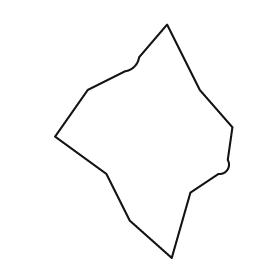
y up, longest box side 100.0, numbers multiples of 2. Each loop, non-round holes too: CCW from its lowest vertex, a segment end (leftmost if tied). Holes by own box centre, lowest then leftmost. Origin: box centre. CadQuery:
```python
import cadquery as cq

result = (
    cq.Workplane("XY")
    .moveTo(12.0, -50.0)
    .lineTo(20.0, -22.0)
    .lineTo(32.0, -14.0)
    .threePointArc((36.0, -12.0), (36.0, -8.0))
    .lineTo(38.0, 6.0)
    .lineTo(24.0, 22.0)
    .lineTo(10.0, 50.0)
    .lineTo(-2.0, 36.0)
    .threePointArc((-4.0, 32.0), (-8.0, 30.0))
    .lineTo(-24.0, 22.0)
    .lineTo(-38.0, 2.0)
    .lineTo(-16.0, -14.0)
    .lineTo(-6.0, -34.0)
    .close()
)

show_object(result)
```